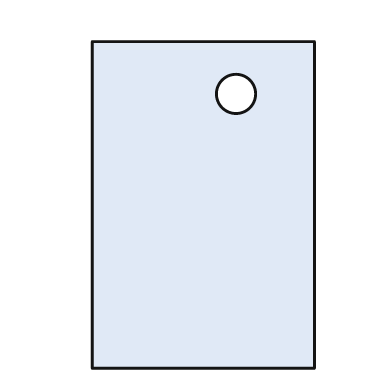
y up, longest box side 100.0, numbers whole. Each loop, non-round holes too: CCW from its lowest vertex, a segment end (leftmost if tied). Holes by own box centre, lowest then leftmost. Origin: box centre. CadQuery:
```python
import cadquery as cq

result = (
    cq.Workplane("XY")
    .moveTo(-34.0, -50.0)
    .lineTo(34.0, -50.0)
    .lineTo(34.0, 50.0)
    .lineTo(-34.0, 50.0)
    .close()
    .moveTo(10.0, 34.0)
    .circle(6.0)
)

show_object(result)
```